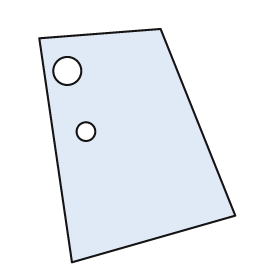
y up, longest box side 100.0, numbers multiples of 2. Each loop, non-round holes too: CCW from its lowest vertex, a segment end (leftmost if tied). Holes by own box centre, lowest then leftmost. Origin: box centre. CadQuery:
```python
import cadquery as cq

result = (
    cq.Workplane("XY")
    .moveTo(-28.0, -50.0)
    .lineTo(42.0, -30.0)
    .lineTo(10.0, 50.0)
    .lineTo(-42.0, 46.0)
    .close()
    .moveTo(-22.0, 6.0)
    .circle(4.0)
    .moveTo(-30.0, 32.0)
    .circle(6.0)
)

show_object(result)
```